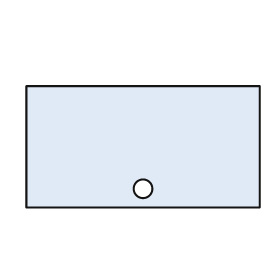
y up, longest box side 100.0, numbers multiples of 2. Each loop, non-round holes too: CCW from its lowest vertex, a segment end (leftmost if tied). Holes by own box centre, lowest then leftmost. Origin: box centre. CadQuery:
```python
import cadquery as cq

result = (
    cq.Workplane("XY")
    .moveTo(-50.0, -26.0)
    .lineTo(50.0, -26.0)
    .lineTo(50.0, 26.0)
    .lineTo(-50.0, 26.0)
    .close()
    .moveTo(0.0, -18.0)
    .circle(4.0)
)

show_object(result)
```